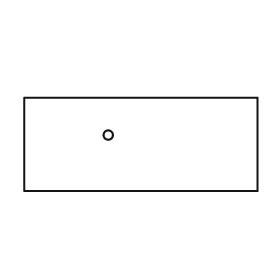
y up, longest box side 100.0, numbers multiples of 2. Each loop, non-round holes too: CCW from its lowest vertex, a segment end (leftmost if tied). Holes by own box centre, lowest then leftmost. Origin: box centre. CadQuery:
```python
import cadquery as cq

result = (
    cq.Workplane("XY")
    .moveTo(-50.0, -20.0)
    .lineTo(50.0, -20.0)
    .lineTo(50.0, 20.0)
    .lineTo(-50.0, 20.0)
    .close()
    .moveTo(-14.0, 4.0)
    .circle(2.0)
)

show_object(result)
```